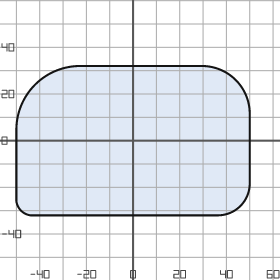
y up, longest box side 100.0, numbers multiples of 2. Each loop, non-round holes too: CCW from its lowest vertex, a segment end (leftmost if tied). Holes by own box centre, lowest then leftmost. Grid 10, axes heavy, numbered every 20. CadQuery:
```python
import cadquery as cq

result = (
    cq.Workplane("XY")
    .moveTo(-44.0, -32.0)
    .lineTo(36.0, -32.0)
    .threePointArc((46.0, -28.0), (50.0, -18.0))
    .lineTo(50.0, 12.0)
    .threePointArc((44.0, 26.0), (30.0, 32.0))
    .lineTo(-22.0, 32.0)
    .threePointArc((-42.0, 24.0), (-50.0, 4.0))
    .lineTo(-50.0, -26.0)
    .threePointArc((-48.0, -30.0), (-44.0, -32.0))
    .close()
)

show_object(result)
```